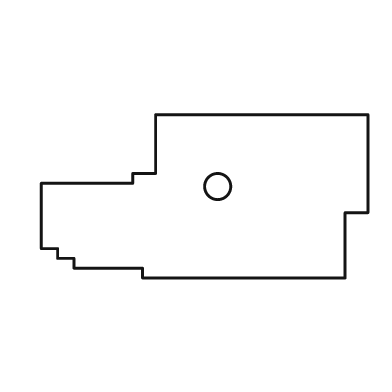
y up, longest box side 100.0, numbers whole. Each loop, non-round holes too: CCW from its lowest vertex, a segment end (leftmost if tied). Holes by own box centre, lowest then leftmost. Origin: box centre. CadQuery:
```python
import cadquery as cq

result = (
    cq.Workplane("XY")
    .moveTo(-19.0, -25.0)
    .lineTo(43.0, -25.0)
    .lineTo(43.0, -5.0)
    .lineTo(50.0, -5.0)
    .lineTo(50.0, 25.0)
    .lineTo(-15.0, 25.0)
    .lineTo(-15.0, 7.0)
    .lineTo(-22.0, 7.0)
    .lineTo(-22.0, 4.0)
    .lineTo(-50.0, 4.0)
    .lineTo(-50.0, -16.0)
    .lineTo(-45.0, -16.0)
    .lineTo(-45.0, -19.0)
    .lineTo(-40.0, -19.0)
    .lineTo(-40.0, -22.0)
    .lineTo(-19.0, -22.0)
    .close()
    .moveTo(4.0, 3.0)
    .circle(4.0)
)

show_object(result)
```